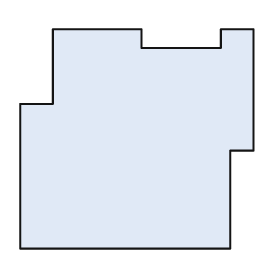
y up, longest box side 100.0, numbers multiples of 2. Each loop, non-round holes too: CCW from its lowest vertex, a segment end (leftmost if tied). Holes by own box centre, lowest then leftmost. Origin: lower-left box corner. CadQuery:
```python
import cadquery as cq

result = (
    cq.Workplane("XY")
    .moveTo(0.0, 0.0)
    .lineTo(90.0, 0.0)
    .lineTo(90.0, 42.0)
    .lineTo(100.0, 42.0)
    .lineTo(100.0, 94.0)
    .lineTo(86.0, 94.0)
    .lineTo(86.0, 86.0)
    .lineTo(52.0, 86.0)
    .lineTo(52.0, 94.0)
    .lineTo(14.0, 94.0)
    .lineTo(14.0, 62.0)
    .lineTo(0.0, 62.0)
    .close()
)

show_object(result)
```